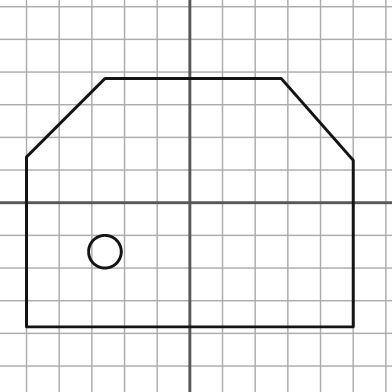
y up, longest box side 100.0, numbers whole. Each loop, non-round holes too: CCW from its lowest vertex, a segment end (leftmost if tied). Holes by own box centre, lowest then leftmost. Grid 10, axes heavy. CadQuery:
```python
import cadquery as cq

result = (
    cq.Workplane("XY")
    .moveTo(-50.0, -38.0)
    .lineTo(50.0, -38.0)
    .lineTo(50.0, 13.0)
    .lineTo(28.0, 38.0)
    .lineTo(-26.0, 38.0)
    .lineTo(-50.0, 14.0)
    .close()
    .moveTo(-26.0, -15.0)
    .circle(5.0)
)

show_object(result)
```